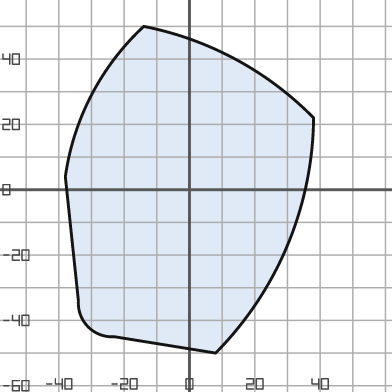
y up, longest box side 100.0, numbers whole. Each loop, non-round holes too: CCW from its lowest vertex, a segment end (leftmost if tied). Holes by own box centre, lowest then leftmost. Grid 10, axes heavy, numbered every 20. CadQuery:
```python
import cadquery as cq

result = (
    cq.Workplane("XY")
    .moveTo(8.0, -50.0)
    .threePointArc((30.0, -17.0), (38.0, 22.0))
    .threePointArc((14.0, 40.0), (-14.0, 50.0))
    .threePointArc((-30.0, 29.0), (-38.0, 4.0))
    .lineTo(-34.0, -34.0)
    .threePointArc((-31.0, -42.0), (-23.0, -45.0))
    .close()
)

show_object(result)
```